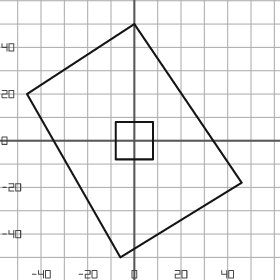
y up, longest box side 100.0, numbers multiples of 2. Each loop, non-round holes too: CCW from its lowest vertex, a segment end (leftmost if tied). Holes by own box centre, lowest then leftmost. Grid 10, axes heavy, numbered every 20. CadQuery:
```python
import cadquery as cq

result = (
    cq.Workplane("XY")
    .moveTo(-6.0, -50.0)
    .lineTo(46.0, -18.0)
    .lineTo(0.0, 50.0)
    .lineTo(-46.0, 20.0)
    .close()
    .moveTo(-8.0, -8.0)
    .lineTo(8.0, -8.0)
    .lineTo(8.0, 8.0)
    .lineTo(-8.0, 8.0)
    .close()
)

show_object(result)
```